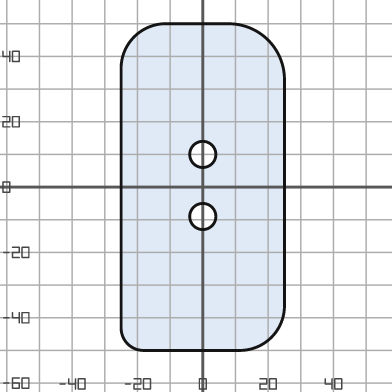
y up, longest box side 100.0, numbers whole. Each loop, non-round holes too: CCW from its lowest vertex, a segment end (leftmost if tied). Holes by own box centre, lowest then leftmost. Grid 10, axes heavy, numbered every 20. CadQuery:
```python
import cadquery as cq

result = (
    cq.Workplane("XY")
    .moveTo(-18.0, -50.0)
    .lineTo(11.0, -50.0)
    .threePointArc((21.0, -46.0), (25.0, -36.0))
    .lineTo(25.0, 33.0)
    .threePointArc((20.0, 45.0), (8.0, 50.0))
    .lineTo(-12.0, 50.0)
    .threePointArc((-21.0, 46.0), (-25.0, 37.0))
    .lineTo(-25.0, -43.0)
    .threePointArc((-23.0, -48.0), (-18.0, -50.0))
    .close()
    .moveTo(0.0, -9.0)
    .circle(4.0)
    .moveTo(0.0, 10.0)
    .circle(4.0)
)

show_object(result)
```